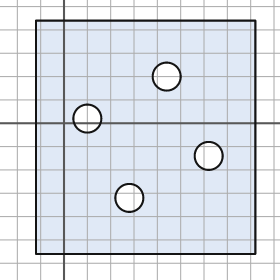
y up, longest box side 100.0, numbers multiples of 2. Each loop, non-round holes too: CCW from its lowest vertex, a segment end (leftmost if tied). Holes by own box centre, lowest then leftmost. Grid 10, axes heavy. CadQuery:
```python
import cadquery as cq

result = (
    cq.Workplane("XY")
    .moveTo(-12.0, -56.0)
    .lineTo(82.0, -56.0)
    .lineTo(82.0, 44.0)
    .lineTo(-12.0, 44.0)
    .close()
    .moveTo(28.0, -32.0)
    .circle(6.0)
    .moveTo(62.0, -14.0)
    .circle(6.0)
    .moveTo(10.0, 2.0)
    .circle(6.0)
    .moveTo(44.0, 20.0)
    .circle(6.0)
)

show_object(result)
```